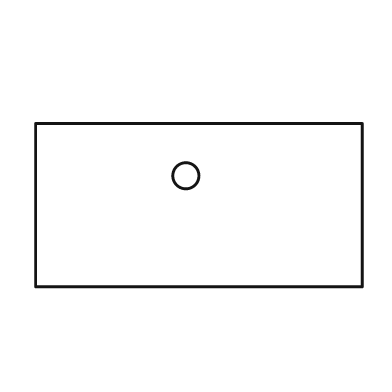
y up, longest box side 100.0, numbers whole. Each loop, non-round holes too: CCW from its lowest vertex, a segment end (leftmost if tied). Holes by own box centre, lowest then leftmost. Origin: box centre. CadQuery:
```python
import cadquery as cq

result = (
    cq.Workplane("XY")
    .moveTo(-50.0, -25.0)
    .lineTo(50.0, -25.0)
    .lineTo(50.0, 25.0)
    .lineTo(-50.0, 25.0)
    .close()
    .moveTo(-4.0, 9.0)
    .circle(4.0)
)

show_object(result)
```